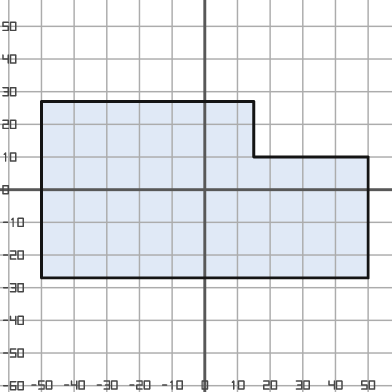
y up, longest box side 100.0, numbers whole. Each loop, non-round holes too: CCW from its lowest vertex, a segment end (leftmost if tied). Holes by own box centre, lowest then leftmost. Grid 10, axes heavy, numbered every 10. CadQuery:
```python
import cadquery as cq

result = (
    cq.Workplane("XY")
    .moveTo(-50.0, -27.0)
    .lineTo(50.0, -27.0)
    .lineTo(50.0, 10.0)
    .lineTo(15.0, 10.0)
    .lineTo(15.0, 27.0)
    .lineTo(-50.0, 27.0)
    .close()
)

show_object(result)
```